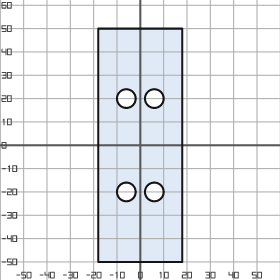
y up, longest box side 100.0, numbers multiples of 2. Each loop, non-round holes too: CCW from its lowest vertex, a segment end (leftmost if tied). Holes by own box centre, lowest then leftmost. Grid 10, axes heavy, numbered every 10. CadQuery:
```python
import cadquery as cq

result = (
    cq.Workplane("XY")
    .moveTo(-18.0, -50.0)
    .lineTo(18.0, -50.0)
    .lineTo(18.0, 50.0)
    .lineTo(-18.0, 50.0)
    .close()
    .moveTo(-6.0, -20.0)
    .circle(4.0)
    .moveTo(6.0, -20.0)
    .circle(4.0)
    .moveTo(-6.0, 20.0)
    .circle(4.0)
    .moveTo(6.0, 20.0)
    .circle(4.0)
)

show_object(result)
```